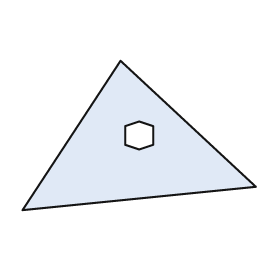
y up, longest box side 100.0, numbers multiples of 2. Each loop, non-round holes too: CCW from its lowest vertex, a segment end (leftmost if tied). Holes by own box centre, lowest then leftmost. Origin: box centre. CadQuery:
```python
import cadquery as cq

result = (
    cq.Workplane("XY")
    .moveTo(-50.0, -32.0)
    .lineTo(50.0, -22.0)
    .lineTo(-8.0, 32.0)
    .close()
    .moveTo(0.0, -6.0)
    .lineTo(6.0, -4.0)
    .lineTo(6.0, 4.0)
    .lineTo(0.0, 6.0)
    .lineTo(-6.0, 4.0)
    .lineTo(-6.0, -4.0)
    .close()
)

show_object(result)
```